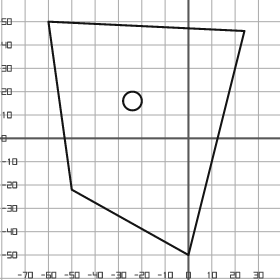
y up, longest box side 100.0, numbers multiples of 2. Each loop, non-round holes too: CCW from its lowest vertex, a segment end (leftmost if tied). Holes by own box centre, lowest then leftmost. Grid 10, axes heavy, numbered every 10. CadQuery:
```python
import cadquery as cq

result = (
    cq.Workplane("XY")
    .moveTo(0.0, -50.0)
    .lineTo(24.0, 46.0)
    .lineTo(-60.0, 50.0)
    .lineTo(-50.0, -22.0)
    .close()
    .moveTo(-24.0, 16.0)
    .circle(4.0)
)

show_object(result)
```